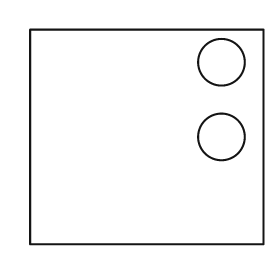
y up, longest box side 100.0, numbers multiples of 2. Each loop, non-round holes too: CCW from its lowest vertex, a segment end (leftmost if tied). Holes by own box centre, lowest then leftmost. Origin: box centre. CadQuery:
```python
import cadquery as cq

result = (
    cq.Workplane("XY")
    .moveTo(-50.0, -46.0)
    .lineTo(50.0, -46.0)
    .lineTo(50.0, 46.0)
    .lineTo(-50.0, 46.0)
    .close()
    .moveTo(32.0, 0.0)
    .circle(10.0)
    .moveTo(32.0, 32.0)
    .circle(10.0)
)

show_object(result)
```